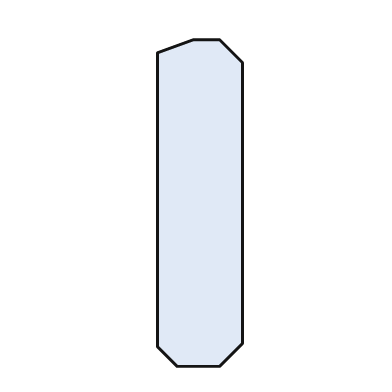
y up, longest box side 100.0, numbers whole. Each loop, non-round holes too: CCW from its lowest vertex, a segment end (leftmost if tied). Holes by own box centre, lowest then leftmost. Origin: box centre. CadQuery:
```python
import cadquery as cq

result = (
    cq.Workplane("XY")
    .moveTo(-7.0, -50.0)
    .lineTo(6.0, -50.0)
    .lineTo(13.0, -43.0)
    .lineTo(13.0, 43.0)
    .lineTo(6.0, 50.0)
    .lineTo(-2.0, 50.0)
    .lineTo(-13.0, 46.0)
    .lineTo(-13.0, -44.0)
    .close()
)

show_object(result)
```